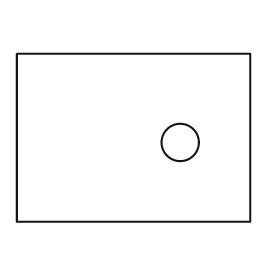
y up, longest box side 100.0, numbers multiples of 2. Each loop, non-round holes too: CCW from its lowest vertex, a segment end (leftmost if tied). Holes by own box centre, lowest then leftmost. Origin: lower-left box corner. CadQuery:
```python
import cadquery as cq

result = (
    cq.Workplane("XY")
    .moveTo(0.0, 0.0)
    .lineTo(100.0, 0.0)
    .lineTo(100.0, 72.0)
    .lineTo(0.0, 72.0)
    .close()
    .moveTo(70.0, 34.0)
    .circle(8.0)
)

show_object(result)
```